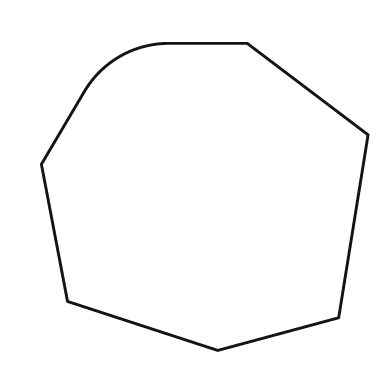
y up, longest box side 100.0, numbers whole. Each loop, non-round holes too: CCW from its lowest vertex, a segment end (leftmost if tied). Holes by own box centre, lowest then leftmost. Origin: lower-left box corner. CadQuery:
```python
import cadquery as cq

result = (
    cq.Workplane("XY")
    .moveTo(54.0, 0.0)
    .lineTo(91.0, 10.0)
    .lineTo(100.0, 66.0)
    .lineTo(63.0, 94.0)
    .lineTo(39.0, 94.0)
    .threePointArc((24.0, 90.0), (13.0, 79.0))
    .lineTo(0.0, 57.0)
    .lineTo(8.0, 15.0)
    .close()
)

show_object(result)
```